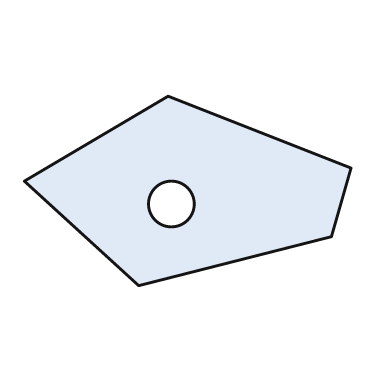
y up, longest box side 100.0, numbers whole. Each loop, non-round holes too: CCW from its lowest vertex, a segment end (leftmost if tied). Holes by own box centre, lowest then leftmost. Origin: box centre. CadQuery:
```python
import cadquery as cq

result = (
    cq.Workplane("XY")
    .moveTo(-15.0, -29.0)
    .lineTo(44.0, -14.0)
    .lineTo(50.0, 7.0)
    .lineTo(-6.0, 29.0)
    .lineTo(-50.0, 3.0)
    .close()
    .moveTo(-5.0, -4.0)
    .circle(7.0)
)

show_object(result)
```